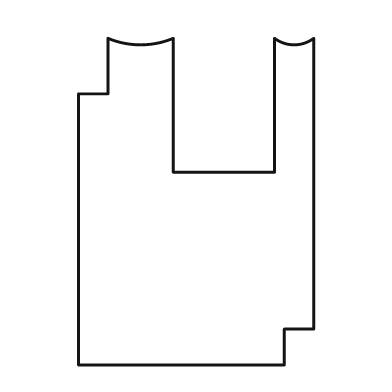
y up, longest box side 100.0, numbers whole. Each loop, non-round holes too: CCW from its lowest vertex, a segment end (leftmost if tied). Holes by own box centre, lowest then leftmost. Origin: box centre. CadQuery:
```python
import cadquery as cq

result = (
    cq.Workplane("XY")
    .moveTo(-36.0, -50.0)
    .lineTo(27.0, -50.0)
    .lineTo(27.0, -39.0)
    .lineTo(36.0, -39.0)
    .lineTo(36.0, 50.0)
    .threePointArc((30.0, 48.0), (24.0, 50.0))
    .lineTo(24.0, 9.0)
    .lineTo(-7.0, 9.0)
    .lineTo(-7.0, 50.0)
    .threePointArc((-17.0, 48.0), (-27.0, 50.0))
    .lineTo(-27.0, 33.0)
    .lineTo(-36.0, 33.0)
    .close()
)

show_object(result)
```